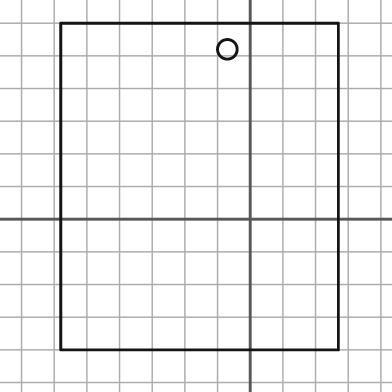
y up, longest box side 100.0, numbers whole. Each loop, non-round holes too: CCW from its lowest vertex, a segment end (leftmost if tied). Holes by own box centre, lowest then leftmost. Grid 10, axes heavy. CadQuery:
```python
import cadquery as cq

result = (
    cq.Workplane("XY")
    .moveTo(-58.0, -40.0)
    .lineTo(27.0, -40.0)
    .lineTo(27.0, 60.0)
    .lineTo(-58.0, 60.0)
    .close()
    .moveTo(-7.0, 52.0)
    .circle(3.0)
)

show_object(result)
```